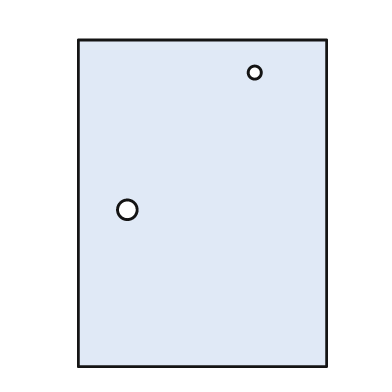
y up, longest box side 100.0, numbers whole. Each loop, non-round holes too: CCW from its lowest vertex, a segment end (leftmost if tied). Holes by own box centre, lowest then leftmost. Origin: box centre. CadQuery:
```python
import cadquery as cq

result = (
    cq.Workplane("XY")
    .moveTo(-38.0, -50.0)
    .lineTo(38.0, -50.0)
    .lineTo(38.0, 50.0)
    .lineTo(-38.0, 50.0)
    .close()
    .moveTo(-23.0, -2.0)
    .circle(3.0)
    .moveTo(16.0, 40.0)
    .circle(2.0)
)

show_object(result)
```